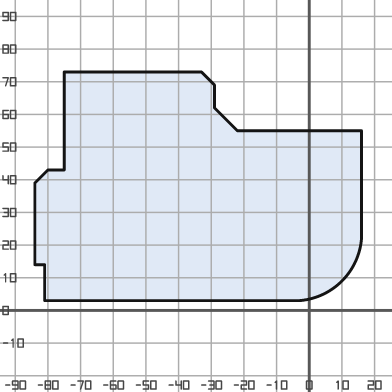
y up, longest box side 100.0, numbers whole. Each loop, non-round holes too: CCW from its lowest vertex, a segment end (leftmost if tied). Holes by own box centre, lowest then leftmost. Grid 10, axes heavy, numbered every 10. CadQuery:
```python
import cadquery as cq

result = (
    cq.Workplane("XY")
    .moveTo(-81.0, 3.0)
    .lineTo(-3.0, 3.0)
    .threePointArc((10.0, 9.0), (16.0, 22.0))
    .lineTo(16.0, 55.0)
    .lineTo(-22.0, 55.0)
    .lineTo(-29.0, 62.0)
    .lineTo(-29.0, 69.0)
    .lineTo(-33.0, 73.0)
    .lineTo(-75.0, 73.0)
    .lineTo(-75.0, 43.0)
    .lineTo(-80.0, 43.0)
    .lineTo(-84.0, 39.0)
    .lineTo(-84.0, 14.0)
    .lineTo(-81.0, 14.0)
    .close()
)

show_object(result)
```